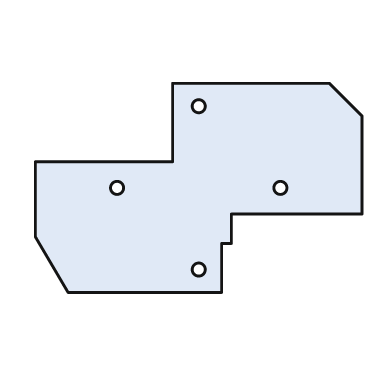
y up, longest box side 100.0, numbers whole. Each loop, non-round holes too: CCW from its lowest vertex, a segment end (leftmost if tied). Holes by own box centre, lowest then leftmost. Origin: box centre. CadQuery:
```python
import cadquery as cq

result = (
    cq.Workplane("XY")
    .moveTo(-40.0, -32.0)
    .lineTo(7.0, -32.0)
    .lineTo(7.0, -17.0)
    .lineTo(10.0, -17.0)
    .lineTo(10.0, -8.0)
    .lineTo(50.0, -8.0)
    .lineTo(50.0, 22.0)
    .lineTo(40.0, 32.0)
    .lineTo(-8.0, 32.0)
    .lineTo(-8.0, 8.0)
    .lineTo(-50.0, 8.0)
    .lineTo(-50.0, -15.0)
    .close()
    .moveTo(0.0, -25.0)
    .circle(2.0)
    .moveTo(-25.0, 0.0)
    .circle(2.0)
    .moveTo(25.0, 0.0)
    .circle(2.0)
    .moveTo(0.0, 25.0)
    .circle(2.0)
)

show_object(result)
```